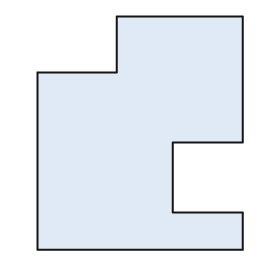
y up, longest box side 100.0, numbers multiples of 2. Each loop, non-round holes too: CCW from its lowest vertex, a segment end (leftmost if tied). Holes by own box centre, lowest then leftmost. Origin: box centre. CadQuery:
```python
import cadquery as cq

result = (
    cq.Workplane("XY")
    .moveTo(-44.0, -50.0)
    .lineTo(44.0, -50.0)
    .lineTo(44.0, -34.0)
    .lineTo(14.0, -34.0)
    .lineTo(14.0, -4.0)
    .lineTo(44.0, -4.0)
    .lineTo(44.0, 50.0)
    .lineTo(-10.0, 50.0)
    .lineTo(-10.0, 26.0)
    .lineTo(-44.0, 26.0)
    .close()
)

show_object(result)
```